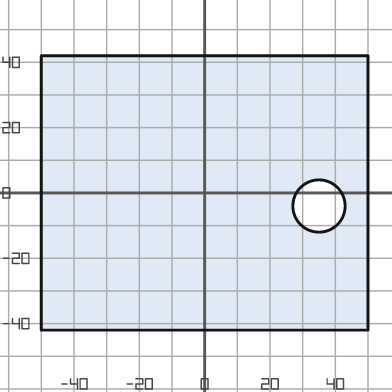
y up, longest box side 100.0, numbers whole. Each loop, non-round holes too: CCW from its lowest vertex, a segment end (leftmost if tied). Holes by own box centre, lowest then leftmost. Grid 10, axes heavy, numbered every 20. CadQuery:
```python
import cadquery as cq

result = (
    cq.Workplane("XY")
    .moveTo(-50.0, -42.0)
    .lineTo(50.0, -42.0)
    .lineTo(50.0, 42.0)
    .lineTo(-50.0, 42.0)
    .close()
    .moveTo(35.0, -4.0)
    .circle(8.0)
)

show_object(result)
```